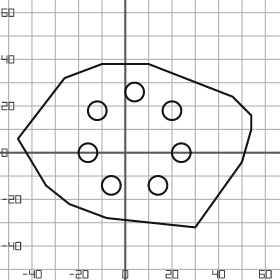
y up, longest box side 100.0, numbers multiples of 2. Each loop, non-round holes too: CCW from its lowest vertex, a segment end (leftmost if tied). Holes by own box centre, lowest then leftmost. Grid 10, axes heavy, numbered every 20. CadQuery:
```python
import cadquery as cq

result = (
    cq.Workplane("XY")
    .moveTo(30.0, -32.0)
    .lineTo(50.0, -4.0)
    .lineTo(54.0, 10.0)
    .lineTo(54.0, 16.0)
    .lineTo(46.0, 24.0)
    .lineTo(10.0, 38.0)
    .lineTo(-10.0, 38.0)
    .lineTo(-26.0, 32.0)
    .lineTo(-46.0, 6.0)
    .lineTo(-34.0, -14.0)
    .lineTo(-24.0, -22.0)
    .lineTo(-8.0, -28.0)
    .close()
    .moveTo(-6.0, -14.0)
    .circle(4.0)
    .moveTo(14.0, -14.0)
    .circle(4.0)
    .moveTo(-16.0, 0.0)
    .circle(4.0)
    .moveTo(24.0, 0.0)
    .circle(4.0)
    .moveTo(-12.0, 18.0)
    .circle(4.0)
    .moveTo(20.0, 18.0)
    .circle(4.0)
    .moveTo(4.0, 26.0)
    .circle(4.0)
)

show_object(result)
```